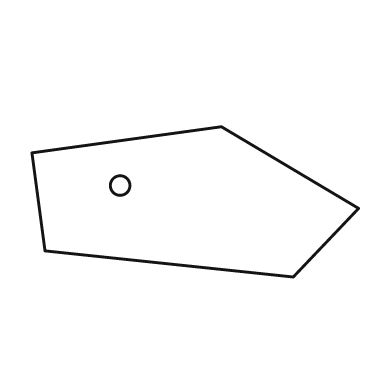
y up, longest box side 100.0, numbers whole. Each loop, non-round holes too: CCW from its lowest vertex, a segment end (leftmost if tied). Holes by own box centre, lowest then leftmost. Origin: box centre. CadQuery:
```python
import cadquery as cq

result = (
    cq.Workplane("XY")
    .moveTo(30.0, -23.0)
    .lineTo(50.0, -2.0)
    .lineTo(8.0, 23.0)
    .lineTo(-50.0, 15.0)
    .lineTo(-46.0, -15.0)
    .close()
    .moveTo(-23.0, 5.0)
    .circle(3.0)
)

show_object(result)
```